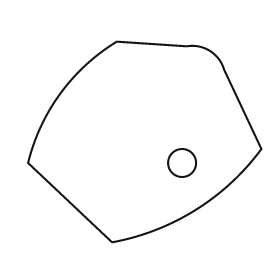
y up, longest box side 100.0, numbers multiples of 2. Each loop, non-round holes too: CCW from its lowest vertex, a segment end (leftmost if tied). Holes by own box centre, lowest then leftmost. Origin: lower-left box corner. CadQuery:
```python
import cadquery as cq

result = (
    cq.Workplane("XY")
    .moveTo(36.0, 0.0)
    .threePointArc((72.0, 14.0), (100.0, 40.0))
    .lineTo(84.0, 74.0)
    .threePointArc((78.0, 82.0), (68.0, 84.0))
    .lineTo(38.0, 86.0)
    .threePointArc((14.0, 64.0), (0.0, 34.0))
    .close()
    .moveTo(66.0, 34.0)
    .circle(6.0)
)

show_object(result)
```